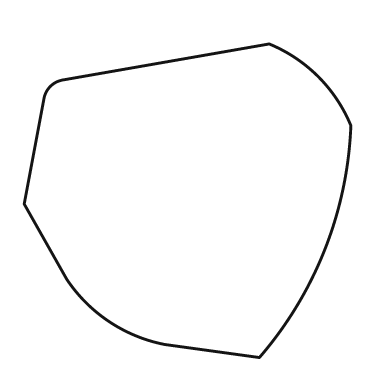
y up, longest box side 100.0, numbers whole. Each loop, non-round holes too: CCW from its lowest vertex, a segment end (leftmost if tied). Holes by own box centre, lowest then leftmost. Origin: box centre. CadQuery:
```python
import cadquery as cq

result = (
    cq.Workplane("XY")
    .moveTo(22.0, -48.0)
    .threePointArc((42.0, -15.0), (50.0, 23.0))
    .threePointArc((40.0, 38.0), (25.0, 48.0))
    .lineTo(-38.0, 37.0)
    .threePointArc((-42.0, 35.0), (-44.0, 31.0))
    .lineTo(-50.0, -1.0)
    .lineTo(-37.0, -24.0)
    .threePointArc((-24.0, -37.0), (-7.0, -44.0))
    .close()
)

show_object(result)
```